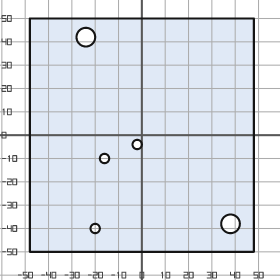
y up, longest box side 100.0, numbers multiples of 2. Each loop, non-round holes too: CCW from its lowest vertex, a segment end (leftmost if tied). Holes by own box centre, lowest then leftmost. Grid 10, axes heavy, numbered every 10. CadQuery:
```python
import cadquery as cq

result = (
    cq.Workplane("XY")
    .moveTo(-48.0, -50.0)
    .lineTo(48.0, -50.0)
    .lineTo(48.0, 50.0)
    .lineTo(-48.0, 50.0)
    .close()
    .moveTo(-20.0, -40.0)
    .circle(2.0)
    .moveTo(38.0, -38.0)
    .circle(4.0)
    .moveTo(-16.0, -10.0)
    .circle(2.0)
    .moveTo(-2.0, -4.0)
    .circle(2.0)
    .moveTo(-24.0, 42.0)
    .circle(4.0)
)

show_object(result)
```